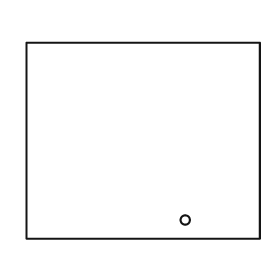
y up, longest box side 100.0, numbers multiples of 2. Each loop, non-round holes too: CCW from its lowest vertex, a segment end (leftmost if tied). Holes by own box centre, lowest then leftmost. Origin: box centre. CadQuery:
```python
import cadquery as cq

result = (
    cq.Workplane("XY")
    .moveTo(-50.0, -42.0)
    .lineTo(50.0, -42.0)
    .lineTo(50.0, 42.0)
    .lineTo(-50.0, 42.0)
    .close()
    .moveTo(18.0, -34.0)
    .circle(2.0)
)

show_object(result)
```